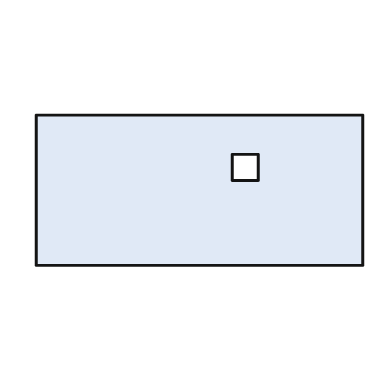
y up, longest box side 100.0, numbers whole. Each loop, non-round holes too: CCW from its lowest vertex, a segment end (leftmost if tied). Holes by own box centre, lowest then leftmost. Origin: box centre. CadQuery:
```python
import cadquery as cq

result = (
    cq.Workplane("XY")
    .moveTo(-50.0, -23.0)
    .lineTo(50.0, -23.0)
    .lineTo(50.0, 23.0)
    .lineTo(-50.0, 23.0)
    .close()
    .moveTo(10.0, 3.0)
    .lineTo(18.0, 3.0)
    .lineTo(18.0, 11.0)
    .lineTo(10.0, 11.0)
    .close()
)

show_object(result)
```